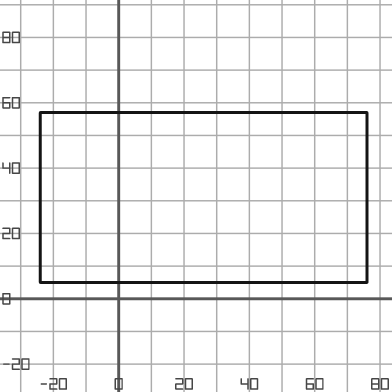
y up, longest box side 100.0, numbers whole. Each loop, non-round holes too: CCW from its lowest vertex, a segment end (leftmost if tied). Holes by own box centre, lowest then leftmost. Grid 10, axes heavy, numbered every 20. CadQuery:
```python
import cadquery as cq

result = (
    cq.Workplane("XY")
    .moveTo(-24.0, 5.0)
    .lineTo(76.0, 5.0)
    .lineTo(76.0, 57.0)
    .lineTo(-24.0, 57.0)
    .close()
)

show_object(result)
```